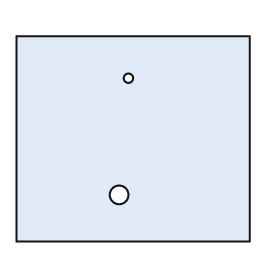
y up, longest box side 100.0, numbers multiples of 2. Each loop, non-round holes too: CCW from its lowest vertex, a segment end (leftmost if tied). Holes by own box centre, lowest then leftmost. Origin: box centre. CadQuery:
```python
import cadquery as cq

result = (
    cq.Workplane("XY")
    .moveTo(-50.0, -44.0)
    .lineTo(50.0, -44.0)
    .lineTo(50.0, 44.0)
    .lineTo(-50.0, 44.0)
    .close()
    .moveTo(-6.0, -24.0)
    .circle(4.0)
    .moveTo(-2.0, 26.0)
    .circle(2.0)
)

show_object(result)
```